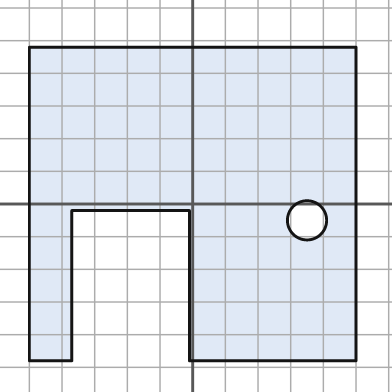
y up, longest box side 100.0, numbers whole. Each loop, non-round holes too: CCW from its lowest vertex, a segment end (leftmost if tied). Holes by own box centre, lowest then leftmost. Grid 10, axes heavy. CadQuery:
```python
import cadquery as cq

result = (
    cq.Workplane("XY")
    .moveTo(-50.0, -48.0)
    .lineTo(-37.0, -48.0)
    .lineTo(-37.0, -2.0)
    .lineTo(-1.0, -2.0)
    .lineTo(-1.0, -48.0)
    .lineTo(50.0, -48.0)
    .lineTo(50.0, 48.0)
    .lineTo(-50.0, 48.0)
    .close()
    .moveTo(35.0, -5.0)
    .circle(6.0)
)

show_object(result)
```